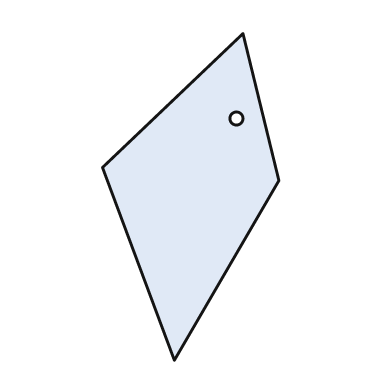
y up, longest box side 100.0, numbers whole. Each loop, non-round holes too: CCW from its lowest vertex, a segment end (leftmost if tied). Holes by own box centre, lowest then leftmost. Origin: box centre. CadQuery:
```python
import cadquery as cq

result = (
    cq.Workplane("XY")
    .moveTo(-5.0, -50.0)
    .lineTo(27.0, 5.0)
    .lineTo(16.0, 50.0)
    .lineTo(-27.0, 9.0)
    .close()
    .moveTo(14.0, 24.0)
    .circle(2.0)
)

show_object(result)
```